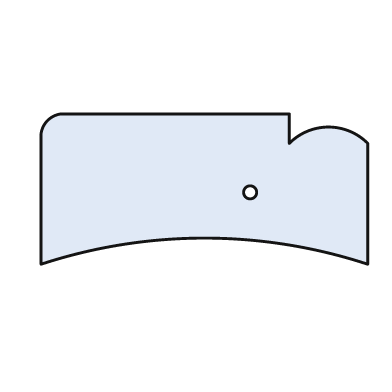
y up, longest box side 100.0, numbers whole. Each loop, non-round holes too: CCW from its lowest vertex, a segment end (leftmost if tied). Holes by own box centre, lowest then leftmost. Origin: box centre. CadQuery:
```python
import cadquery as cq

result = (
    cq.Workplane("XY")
    .moveTo(-50.0, -23.0)
    .threePointArc((0.0, -15.0), (50.0, -23.0))
    .lineTo(50.0, 14.0)
    .threePointArc((38.0, 19.0), (26.0, 14.0))
    .lineTo(26.0, 23.0)
    .lineTo(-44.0, 23.0)
    .threePointArc((-48.0, 21.0), (-50.0, 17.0))
    .close()
    .moveTo(14.0, -1.0)
    .circle(2.0)
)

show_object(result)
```